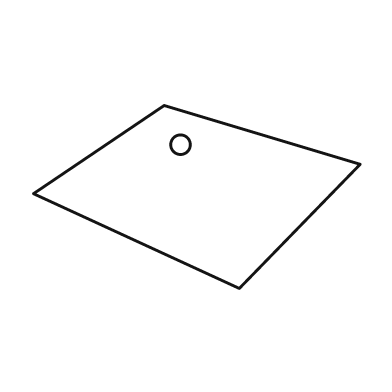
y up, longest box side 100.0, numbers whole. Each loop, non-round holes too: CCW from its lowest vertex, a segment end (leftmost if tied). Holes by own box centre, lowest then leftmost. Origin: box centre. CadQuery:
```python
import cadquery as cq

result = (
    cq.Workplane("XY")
    .moveTo(13.0, -28.0)
    .lineTo(50.0, 10.0)
    .lineTo(-10.0, 28.0)
    .lineTo(-50.0, 1.0)
    .close()
    .moveTo(-5.0, 16.0)
    .circle(3.0)
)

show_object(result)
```